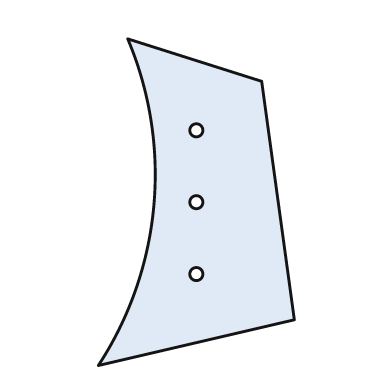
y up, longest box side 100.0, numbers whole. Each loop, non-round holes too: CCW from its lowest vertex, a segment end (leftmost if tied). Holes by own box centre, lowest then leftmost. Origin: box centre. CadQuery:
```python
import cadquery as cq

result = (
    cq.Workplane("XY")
    .moveTo(-30.0, -50.0)
    .lineTo(30.0, -36.0)
    .lineTo(20.0, 37.0)
    .lineTo(-21.0, 50.0)
    .threePointArc((-13.0, -1.0), (-30.0, -50.0))
    .close()
    .moveTo(0.0, -22.0)
    .circle(2.0)
    .moveTo(0.0, 0.0)
    .circle(2.0)
    .moveTo(0.0, 22.0)
    .circle(2.0)
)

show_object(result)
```